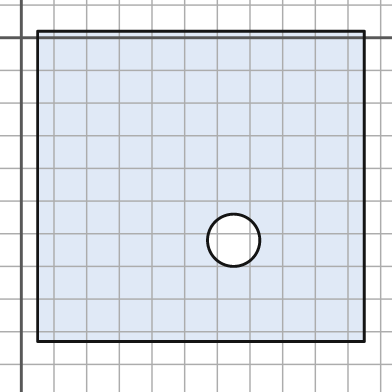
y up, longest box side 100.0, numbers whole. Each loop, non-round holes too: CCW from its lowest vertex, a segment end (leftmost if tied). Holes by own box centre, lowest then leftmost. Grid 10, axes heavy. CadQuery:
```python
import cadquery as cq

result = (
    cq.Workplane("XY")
    .moveTo(5.0, -93.0)
    .lineTo(105.0, -93.0)
    .lineTo(105.0, 2.0)
    .lineTo(5.0, 2.0)
    .close()
    .moveTo(65.0, -62.0)
    .circle(8.0)
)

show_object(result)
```